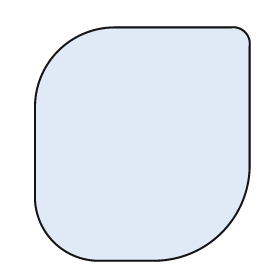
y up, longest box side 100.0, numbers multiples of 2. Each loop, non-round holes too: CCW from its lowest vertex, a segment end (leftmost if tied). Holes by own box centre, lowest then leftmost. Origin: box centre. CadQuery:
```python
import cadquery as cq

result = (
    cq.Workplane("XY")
    .moveTo(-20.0, -50.0)
    .lineTo(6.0, -50.0)
    .threePointArc((34.0, -38.0), (46.0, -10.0))
    .lineTo(46.0, 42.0)
    .threePointArc((44.0, 48.0), (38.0, 50.0))
    .lineTo(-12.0, 50.0)
    .threePointArc((-36.0, 40.0), (-46.0, 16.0))
    .lineTo(-46.0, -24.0)
    .threePointArc((-38.0, -42.0), (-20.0, -50.0))
    .close()
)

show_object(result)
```